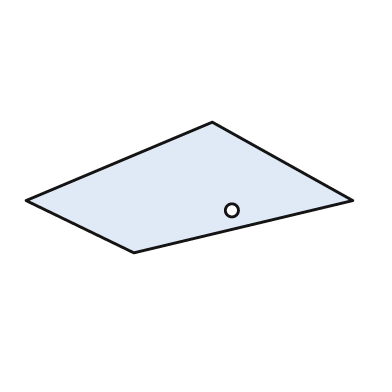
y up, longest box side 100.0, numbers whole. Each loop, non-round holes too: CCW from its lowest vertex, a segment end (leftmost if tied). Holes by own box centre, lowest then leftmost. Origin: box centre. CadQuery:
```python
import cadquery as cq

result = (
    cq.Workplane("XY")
    .moveTo(-17.0, -20.0)
    .lineTo(50.0, -4.0)
    .lineTo(7.0, 20.0)
    .lineTo(-50.0, -4.0)
    .close()
    .moveTo(13.0, -7.0)
    .circle(2.0)
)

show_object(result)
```